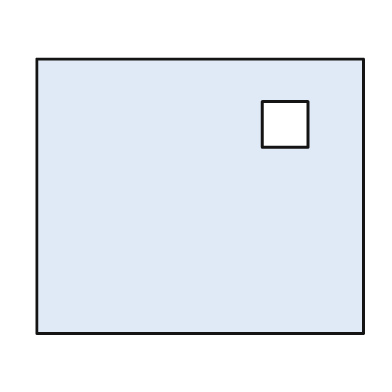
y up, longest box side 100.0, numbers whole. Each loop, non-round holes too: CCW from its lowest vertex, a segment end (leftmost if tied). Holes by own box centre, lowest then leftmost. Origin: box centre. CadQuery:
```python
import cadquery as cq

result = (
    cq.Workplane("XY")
    .moveTo(-50.0, -42.0)
    .lineTo(50.0, -42.0)
    .lineTo(50.0, 42.0)
    .lineTo(-50.0, 42.0)
    .close()
    .moveTo(19.0, 15.0)
    .lineTo(33.0, 15.0)
    .lineTo(33.0, 29.0)
    .lineTo(19.0, 29.0)
    .close()
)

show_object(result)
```